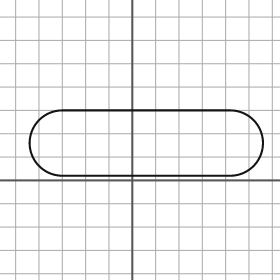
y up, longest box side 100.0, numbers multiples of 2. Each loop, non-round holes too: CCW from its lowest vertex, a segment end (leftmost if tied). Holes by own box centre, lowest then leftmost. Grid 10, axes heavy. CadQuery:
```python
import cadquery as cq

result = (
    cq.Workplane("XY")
    .moveTo(-30.0, 2.0)
    .lineTo(42.0, 2.0)
    .threePointArc((56.0, 16.0), (42.0, 30.0))
    .lineTo(-30.0, 30.0)
    .threePointArc((-44.0, 16.0), (-30.0, 2.0))
    .close()
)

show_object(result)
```